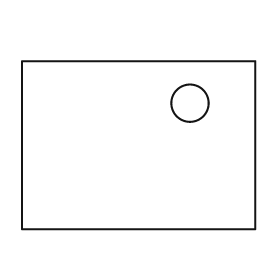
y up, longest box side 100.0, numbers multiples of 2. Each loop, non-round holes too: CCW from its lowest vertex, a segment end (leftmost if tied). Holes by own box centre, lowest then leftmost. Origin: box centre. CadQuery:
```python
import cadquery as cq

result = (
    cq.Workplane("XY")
    .moveTo(-50.0, -36.0)
    .lineTo(50.0, -36.0)
    .lineTo(50.0, 36.0)
    .lineTo(-50.0, 36.0)
    .close()
    .moveTo(22.0, 18.0)
    .circle(8.0)
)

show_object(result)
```